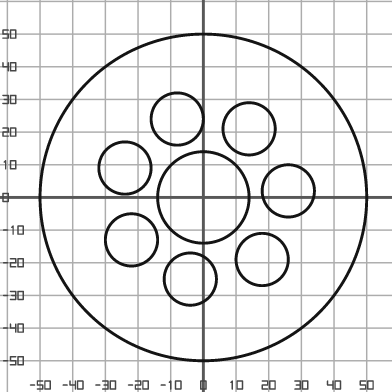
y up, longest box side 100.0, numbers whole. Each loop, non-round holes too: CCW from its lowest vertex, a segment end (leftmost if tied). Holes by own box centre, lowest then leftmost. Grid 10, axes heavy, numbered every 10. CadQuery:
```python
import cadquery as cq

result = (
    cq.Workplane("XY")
    .moveTo(0.0, 0.0)
    .circle(50.0)
    .moveTo(-4.0, -25.0)
    .circle(8.0)
    .moveTo(18.0, -19.0)
    .circle(8.0)
    .moveTo(-22.0, -13.0)
    .circle(8.0)
    .moveTo(0.0, 0.0)
    .circle(14.0)
    .moveTo(26.0, 2.0)
    .circle(8.0)
    .moveTo(-24.0, 9.0)
    .circle(8.0)
    .moveTo(14.0, 21.0)
    .circle(8.0)
    .moveTo(-8.0, 24.0)
    .circle(8.0)
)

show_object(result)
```